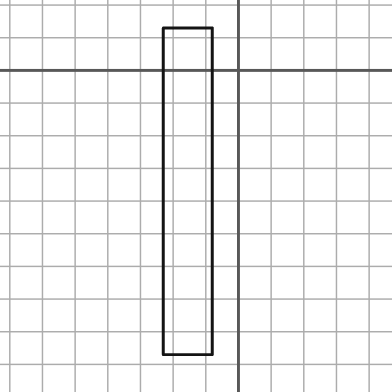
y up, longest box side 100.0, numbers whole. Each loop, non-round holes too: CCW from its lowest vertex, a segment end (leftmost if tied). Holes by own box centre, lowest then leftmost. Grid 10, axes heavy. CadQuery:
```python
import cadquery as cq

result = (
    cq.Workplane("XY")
    .moveTo(-23.0, -87.0)
    .lineTo(-8.0, -87.0)
    .lineTo(-8.0, 13.0)
    .lineTo(-23.0, 13.0)
    .close()
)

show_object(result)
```